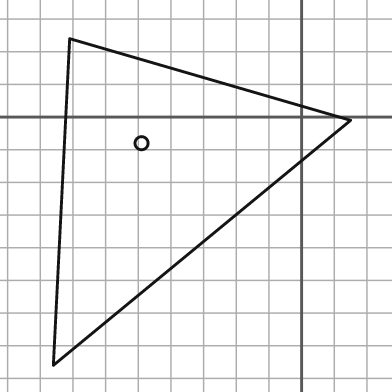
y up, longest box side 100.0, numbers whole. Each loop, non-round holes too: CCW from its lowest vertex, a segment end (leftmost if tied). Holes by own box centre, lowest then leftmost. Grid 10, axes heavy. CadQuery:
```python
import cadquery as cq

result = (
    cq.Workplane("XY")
    .moveTo(-76.0, -76.0)
    .lineTo(15.0, -1.0)
    .lineTo(-71.0, 24.0)
    .close()
    .moveTo(-49.0, -8.0)
    .circle(2.0)
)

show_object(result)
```